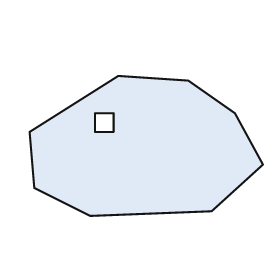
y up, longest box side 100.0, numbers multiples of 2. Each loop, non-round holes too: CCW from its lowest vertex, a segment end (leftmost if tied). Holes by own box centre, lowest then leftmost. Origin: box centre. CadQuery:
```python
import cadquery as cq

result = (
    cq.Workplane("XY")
    .moveTo(-24.0, -30.0)
    .lineTo(28.0, -28.0)
    .lineTo(50.0, -8.0)
    .lineTo(38.0, 14.0)
    .lineTo(18.0, 28.0)
    .lineTo(-12.0, 30.0)
    .lineTo(-50.0, 6.0)
    .lineTo(-48.0, -18.0)
    .close()
    .moveTo(-22.0, 6.0)
    .lineTo(-14.0, 6.0)
    .lineTo(-14.0, 14.0)
    .lineTo(-22.0, 14.0)
    .close()
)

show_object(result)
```